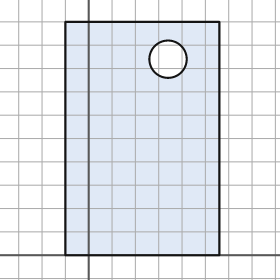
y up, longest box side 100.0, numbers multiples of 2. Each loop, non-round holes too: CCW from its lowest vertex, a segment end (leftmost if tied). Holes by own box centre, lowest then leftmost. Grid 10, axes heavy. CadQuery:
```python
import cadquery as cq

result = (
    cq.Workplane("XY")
    .moveTo(-10.0, 0.0)
    .lineTo(56.0, 0.0)
    .lineTo(56.0, 100.0)
    .lineTo(-10.0, 100.0)
    .close()
    .moveTo(34.0, 84.0)
    .circle(8.0)
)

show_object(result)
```